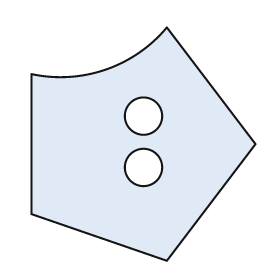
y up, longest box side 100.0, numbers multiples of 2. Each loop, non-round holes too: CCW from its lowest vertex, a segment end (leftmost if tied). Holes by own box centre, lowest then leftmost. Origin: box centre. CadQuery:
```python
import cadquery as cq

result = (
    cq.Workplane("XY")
    .moveTo(10.0, -50.0)
    .lineTo(48.0, 0.0)
    .lineTo(10.0, 50.0)
    .threePointArc((-16.0, 32.0), (-48.0, 30.0))
    .lineTo(-48.0, -30.0)
    .close()
    .moveTo(0.0, -10.0)
    .circle(8.0)
    .moveTo(0.0, 12.0)
    .circle(8.0)
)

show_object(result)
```